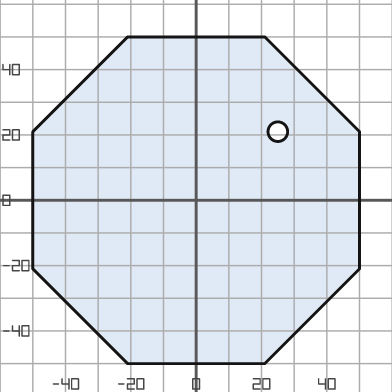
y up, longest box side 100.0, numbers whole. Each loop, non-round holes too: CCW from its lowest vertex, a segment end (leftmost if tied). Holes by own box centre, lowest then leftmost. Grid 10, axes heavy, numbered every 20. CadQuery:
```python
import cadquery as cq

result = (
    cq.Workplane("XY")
    .moveTo(-21.0, -50.0)
    .lineTo(21.0, -50.0)
    .lineTo(50.0, -21.0)
    .lineTo(50.0, 21.0)
    .lineTo(21.0, 50.0)
    .lineTo(-21.0, 50.0)
    .lineTo(-50.0, 21.0)
    .lineTo(-50.0, -21.0)
    .close()
    .moveTo(25.0, 21.0)
    .circle(3.0)
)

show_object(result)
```